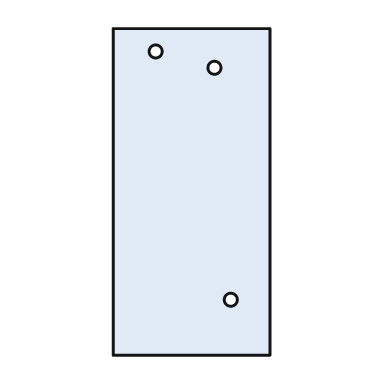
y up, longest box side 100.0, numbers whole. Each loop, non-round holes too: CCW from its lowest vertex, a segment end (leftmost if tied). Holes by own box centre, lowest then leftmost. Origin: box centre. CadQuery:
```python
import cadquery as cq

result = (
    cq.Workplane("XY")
    .moveTo(-24.0, -50.0)
    .lineTo(24.0, -50.0)
    .lineTo(24.0, 50.0)
    .lineTo(-24.0, 50.0)
    .close()
    .moveTo(12.0, -33.0)
    .circle(2.0)
    .moveTo(7.0, 38.0)
    .circle(2.0)
    .moveTo(-11.0, 43.0)
    .circle(2.0)
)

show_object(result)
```